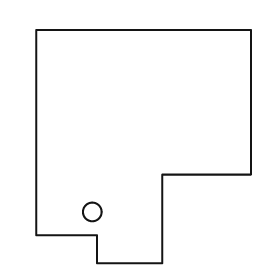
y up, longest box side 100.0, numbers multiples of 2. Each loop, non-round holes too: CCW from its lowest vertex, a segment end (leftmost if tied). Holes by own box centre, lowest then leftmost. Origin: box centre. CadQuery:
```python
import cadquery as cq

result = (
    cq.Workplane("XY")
    .moveTo(-20.0, -50.0)
    .lineTo(8.0, -50.0)
    .lineTo(8.0, -12.0)
    .lineTo(46.0, -12.0)
    .lineTo(46.0, 50.0)
    .lineTo(-46.0, 50.0)
    .lineTo(-46.0, -38.0)
    .lineTo(-20.0, -38.0)
    .close()
    .moveTo(-22.0, -28.0)
    .circle(4.0)
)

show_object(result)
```